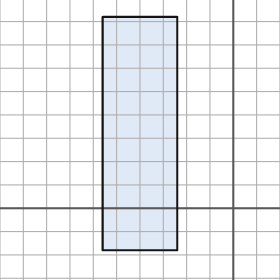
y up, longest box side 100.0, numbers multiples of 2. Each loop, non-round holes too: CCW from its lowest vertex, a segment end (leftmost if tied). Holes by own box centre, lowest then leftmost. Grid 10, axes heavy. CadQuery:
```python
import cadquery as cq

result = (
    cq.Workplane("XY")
    .moveTo(-56.0, -18.0)
    .lineTo(-24.0, -18.0)
    .lineTo(-24.0, 82.0)
    .lineTo(-56.0, 82.0)
    .close()
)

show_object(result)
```